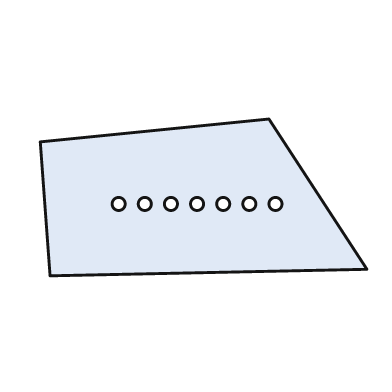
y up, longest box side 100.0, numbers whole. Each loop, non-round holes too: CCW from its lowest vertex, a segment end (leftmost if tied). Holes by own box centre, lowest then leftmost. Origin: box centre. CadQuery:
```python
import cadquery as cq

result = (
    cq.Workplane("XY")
    .moveTo(-47.0, -24.0)
    .lineTo(50.0, -22.0)
    .lineTo(20.0, 24.0)
    .lineTo(-50.0, 17.0)
    .close()
    .moveTo(-26.0, -2.0)
    .circle(2.0)
    .moveTo(-18.0, -2.0)
    .circle(2.0)
    .moveTo(-10.0, -2.0)
    .circle(2.0)
    .moveTo(-2.0, -2.0)
    .circle(2.0)
    .moveTo(6.0, -2.0)
    .circle(2.0)
    .moveTo(14.0, -2.0)
    .circle(2.0)
    .moveTo(22.0, -2.0)
    .circle(2.0)
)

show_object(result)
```